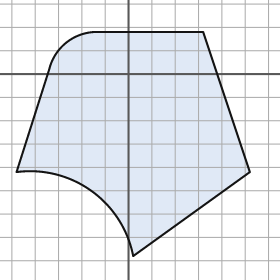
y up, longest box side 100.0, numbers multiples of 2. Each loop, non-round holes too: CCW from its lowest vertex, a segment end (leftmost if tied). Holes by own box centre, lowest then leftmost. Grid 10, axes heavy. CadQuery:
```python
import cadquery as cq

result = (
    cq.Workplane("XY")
    .moveTo(2.0, -78.0)
    .lineTo(52.0, -42.0)
    .lineTo(32.0, 18.0)
    .lineTo(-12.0, 18.0)
    .threePointArc((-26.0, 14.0), (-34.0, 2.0))
    .lineTo(-48.0, -42.0)
    .threePointArc((-16.0, -50.0), (2.0, -78.0))
    .close()
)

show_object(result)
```